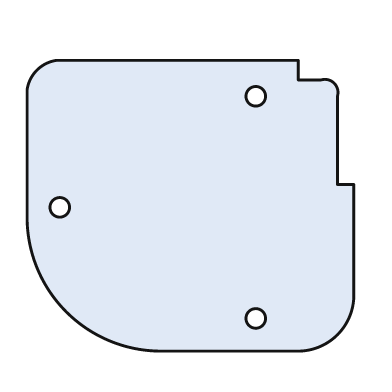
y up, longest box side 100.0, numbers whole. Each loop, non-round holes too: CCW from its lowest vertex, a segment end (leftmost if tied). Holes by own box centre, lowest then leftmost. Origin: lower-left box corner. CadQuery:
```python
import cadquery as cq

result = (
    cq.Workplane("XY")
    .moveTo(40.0, 0.0)
    .lineTo(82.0, 0.0)
    .threePointArc((95.0, 5.0), (100.0, 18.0))
    .lineTo(100.0, 51.0)
    .lineTo(95.0, 51.0)
    .lineTo(95.0, 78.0)
    .threePointArc((94.0, 82.0), (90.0, 83.0))
    .lineTo(83.0, 83.0)
    .lineTo(83.0, 89.0)
    .lineTo(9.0, 89.0)
    .threePointArc((3.0, 86.0), (0.0, 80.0))
    .lineTo(0.0, 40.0)
    .threePointArc((12.0, 12.0), (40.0, 0.0))
    .close()
    .moveTo(70.0, 10.0)
    .circle(3.0)
    .moveTo(10.0, 44.0)
    .circle(3.0)
    .moveTo(70.0, 78.0)
    .circle(3.0)
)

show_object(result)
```